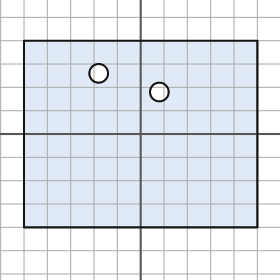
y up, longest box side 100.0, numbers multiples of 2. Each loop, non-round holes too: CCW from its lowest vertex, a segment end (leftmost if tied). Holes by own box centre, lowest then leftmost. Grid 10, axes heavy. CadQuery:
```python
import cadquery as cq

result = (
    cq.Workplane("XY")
    .moveTo(-50.0, -40.0)
    .lineTo(50.0, -40.0)
    .lineTo(50.0, 40.0)
    .lineTo(-50.0, 40.0)
    .close()
    .moveTo(8.0, 18.0)
    .circle(4.0)
    .moveTo(-18.0, 26.0)
    .circle(4.0)
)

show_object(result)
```